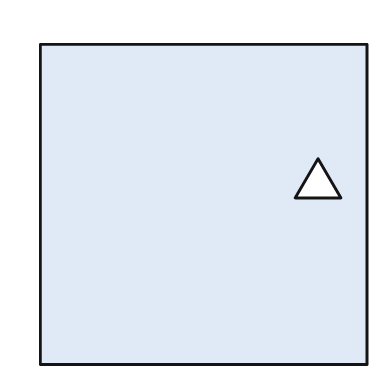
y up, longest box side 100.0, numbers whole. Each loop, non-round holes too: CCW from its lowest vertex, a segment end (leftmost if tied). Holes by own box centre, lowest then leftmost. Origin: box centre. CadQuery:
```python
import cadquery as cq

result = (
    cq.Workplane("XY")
    .moveTo(-50.0, -49.0)
    .lineTo(50.0, -49.0)
    .lineTo(50.0, 49.0)
    .lineTo(-50.0, 49.0)
    .close()
    .moveTo(28.0, 2.0)
    .lineTo(42.0, 2.0)
    .lineTo(35.0, 14.0)
    .close()
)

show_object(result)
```